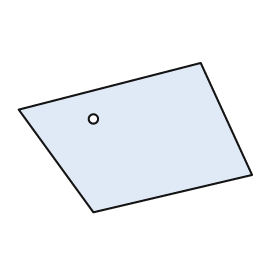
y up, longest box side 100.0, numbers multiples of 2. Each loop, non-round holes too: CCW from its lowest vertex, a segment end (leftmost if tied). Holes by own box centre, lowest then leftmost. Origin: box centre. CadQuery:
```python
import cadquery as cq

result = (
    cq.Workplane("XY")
    .moveTo(-18.0, -32.0)
    .lineTo(50.0, -16.0)
    .lineTo(28.0, 32.0)
    .lineTo(-50.0, 12.0)
    .close()
    .moveTo(-18.0, 8.0)
    .circle(2.0)
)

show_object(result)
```